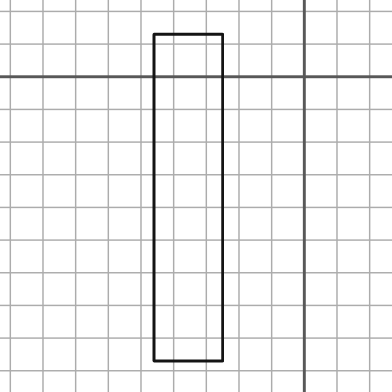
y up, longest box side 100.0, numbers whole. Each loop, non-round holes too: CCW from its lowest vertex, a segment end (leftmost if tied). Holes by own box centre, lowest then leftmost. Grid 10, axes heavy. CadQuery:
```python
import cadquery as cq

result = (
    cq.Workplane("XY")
    .moveTo(-46.0, -87.0)
    .lineTo(-25.0, -87.0)
    .lineTo(-25.0, 13.0)
    .lineTo(-46.0, 13.0)
    .close()
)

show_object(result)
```